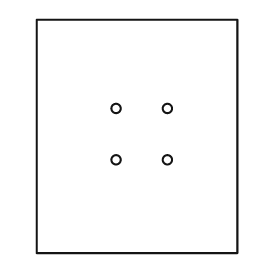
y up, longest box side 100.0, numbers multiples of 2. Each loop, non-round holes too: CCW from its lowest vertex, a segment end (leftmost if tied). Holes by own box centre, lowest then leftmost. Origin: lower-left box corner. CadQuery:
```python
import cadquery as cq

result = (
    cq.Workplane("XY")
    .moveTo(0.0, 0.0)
    .lineTo(86.0, 0.0)
    .lineTo(86.0, 100.0)
    .lineTo(0.0, 100.0)
    .close()
    .moveTo(34.0, 40.0)
    .circle(2.0)
    .moveTo(56.0, 40.0)
    .circle(2.0)
    .moveTo(34.0, 62.0)
    .circle(2.0)
    .moveTo(56.0, 62.0)
    .circle(2.0)
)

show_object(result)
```